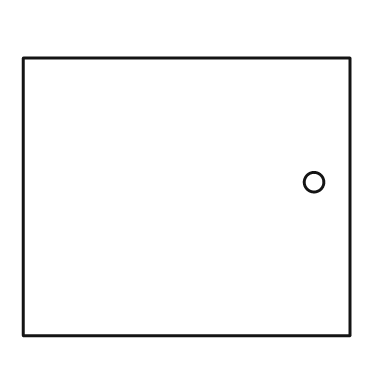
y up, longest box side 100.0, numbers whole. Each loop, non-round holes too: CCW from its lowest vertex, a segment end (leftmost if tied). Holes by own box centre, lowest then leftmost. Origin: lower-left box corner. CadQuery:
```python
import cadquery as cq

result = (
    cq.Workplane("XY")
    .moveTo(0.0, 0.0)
    .lineTo(100.0, 0.0)
    .lineTo(100.0, 85.0)
    .lineTo(0.0, 85.0)
    .close()
    .moveTo(89.0, 47.0)
    .circle(3.0)
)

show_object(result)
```